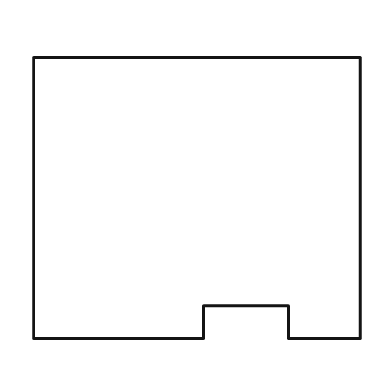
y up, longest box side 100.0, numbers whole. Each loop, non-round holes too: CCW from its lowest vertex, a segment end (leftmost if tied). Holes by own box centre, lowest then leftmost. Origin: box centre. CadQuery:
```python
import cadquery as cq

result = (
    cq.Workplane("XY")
    .moveTo(-50.0, -43.0)
    .lineTo(2.0, -43.0)
    .lineTo(2.0, -33.0)
    .lineTo(28.0, -33.0)
    .lineTo(28.0, -43.0)
    .lineTo(50.0, -43.0)
    .lineTo(50.0, 43.0)
    .lineTo(-50.0, 43.0)
    .close()
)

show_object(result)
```